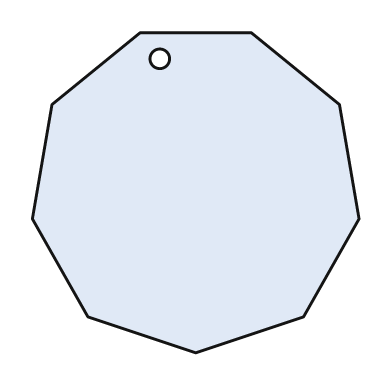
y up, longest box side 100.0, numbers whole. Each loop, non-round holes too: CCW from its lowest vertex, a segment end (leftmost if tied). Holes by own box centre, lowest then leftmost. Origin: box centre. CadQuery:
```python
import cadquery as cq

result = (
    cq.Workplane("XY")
    .moveTo(0.0, -49.0)
    .lineTo(33.0, -38.0)
    .lineTo(50.0, -8.0)
    .lineTo(44.0, 27.0)
    .lineTo(17.0, 49.0)
    .lineTo(-17.0, 49.0)
    .lineTo(-44.0, 27.0)
    .lineTo(-50.0, -8.0)
    .lineTo(-33.0, -38.0)
    .close()
    .moveTo(-11.0, 41.0)
    .circle(3.0)
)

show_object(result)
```